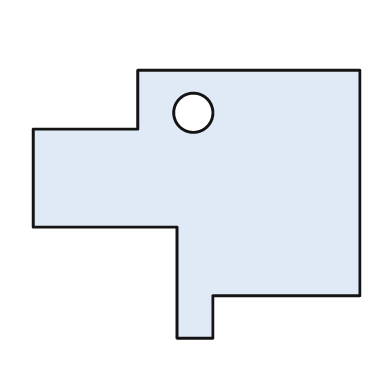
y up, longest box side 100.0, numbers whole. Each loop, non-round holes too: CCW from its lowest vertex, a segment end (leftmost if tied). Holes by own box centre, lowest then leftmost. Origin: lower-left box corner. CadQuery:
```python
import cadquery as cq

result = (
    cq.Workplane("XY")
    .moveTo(44.0, 0.0)
    .lineTo(55.0, 0.0)
    .lineTo(55.0, 13.0)
    .lineTo(100.0, 13.0)
    .lineTo(100.0, 82.0)
    .lineTo(32.0, 82.0)
    .lineTo(32.0, 64.0)
    .lineTo(0.0, 64.0)
    .lineTo(0.0, 34.0)
    .lineTo(44.0, 34.0)
    .close()
    .moveTo(49.0, 69.0)
    .circle(6.0)
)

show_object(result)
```